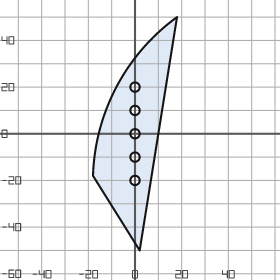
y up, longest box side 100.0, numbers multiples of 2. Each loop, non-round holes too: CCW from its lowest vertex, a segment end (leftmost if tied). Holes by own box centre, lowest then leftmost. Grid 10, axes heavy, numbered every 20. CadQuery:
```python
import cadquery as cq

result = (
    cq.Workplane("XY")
    .moveTo(2.0, -50.0)
    .lineTo(18.0, 50.0)
    .threePointArc((-8.0, 20.0), (-18.0, -18.0))
    .close()
    .moveTo(0.0, -20.0)
    .circle(2.0)
    .moveTo(0.0, -10.0)
    .circle(2.0)
    .moveTo(0.0, 0.0)
    .circle(2.0)
    .moveTo(0.0, 10.0)
    .circle(2.0)
    .moveTo(0.0, 20.0)
    .circle(2.0)
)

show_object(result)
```